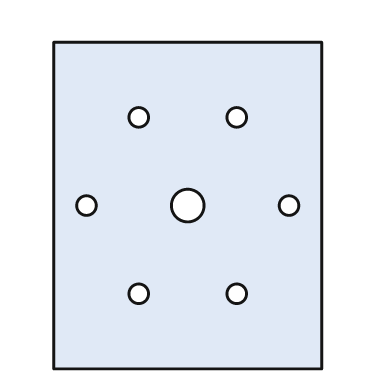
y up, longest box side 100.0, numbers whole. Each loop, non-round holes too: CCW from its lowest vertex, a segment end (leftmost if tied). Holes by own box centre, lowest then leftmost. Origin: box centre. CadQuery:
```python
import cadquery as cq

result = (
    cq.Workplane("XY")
    .moveTo(-41.0, -50.0)
    .lineTo(41.0, -50.0)
    .lineTo(41.0, 50.0)
    .lineTo(-41.0, 50.0)
    .close()
    .moveTo(-15.0, -27.0)
    .circle(3.0)
    .moveTo(15.0, -27.0)
    .circle(3.0)
    .moveTo(-31.0, 0.0)
    .circle(3.0)
    .moveTo(0.0, 0.0)
    .circle(5.0)
    .moveTo(31.0, 0.0)
    .circle(3.0)
    .moveTo(-15.0, 27.0)
    .circle(3.0)
    .moveTo(15.0, 27.0)
    .circle(3.0)
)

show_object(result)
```